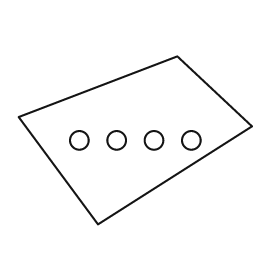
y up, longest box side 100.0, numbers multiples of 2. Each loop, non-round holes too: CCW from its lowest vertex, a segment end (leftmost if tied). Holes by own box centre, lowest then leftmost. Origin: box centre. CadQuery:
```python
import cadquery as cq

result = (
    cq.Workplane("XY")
    .moveTo(-16.0, -36.0)
    .lineTo(50.0, 6.0)
    .lineTo(18.0, 36.0)
    .lineTo(-50.0, 10.0)
    .close()
    .moveTo(-24.0, 0.0)
    .circle(4.0)
    .moveTo(-8.0, 0.0)
    .circle(4.0)
    .moveTo(8.0, 0.0)
    .circle(4.0)
    .moveTo(24.0, 0.0)
    .circle(4.0)
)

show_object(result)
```